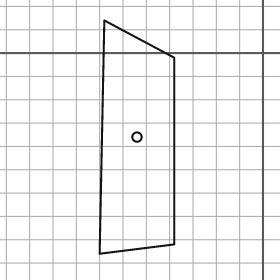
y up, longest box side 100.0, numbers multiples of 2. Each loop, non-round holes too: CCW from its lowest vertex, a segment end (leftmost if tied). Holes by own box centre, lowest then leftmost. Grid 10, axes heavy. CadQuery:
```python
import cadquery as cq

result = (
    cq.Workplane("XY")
    .moveTo(-70.0, -86.0)
    .lineTo(-38.0, -82.0)
    .lineTo(-38.0, -2.0)
    .lineTo(-68.0, 14.0)
    .close()
    .moveTo(-54.0, -36.0)
    .circle(2.0)
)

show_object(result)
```